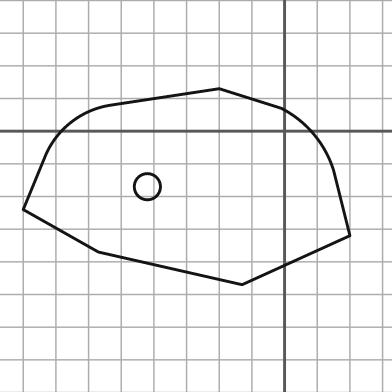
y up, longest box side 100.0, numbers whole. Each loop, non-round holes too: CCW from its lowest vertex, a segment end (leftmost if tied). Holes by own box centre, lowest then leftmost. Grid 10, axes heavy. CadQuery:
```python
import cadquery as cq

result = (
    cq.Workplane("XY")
    .moveTo(-13.0, -47.0)
    .lineTo(20.0, -32.0)
    .lineTo(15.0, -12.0)
    .threePointArc((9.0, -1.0), (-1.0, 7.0))
    .lineTo(-20.0, 13.0)
    .lineTo(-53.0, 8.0)
    .threePointArc((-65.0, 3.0), (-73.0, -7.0))
    .lineTo(-80.0, -24.0)
    .lineTo(-57.0, -37.0)
    .close()
    .moveTo(-42.0, -17.0)
    .circle(4.0)
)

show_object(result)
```